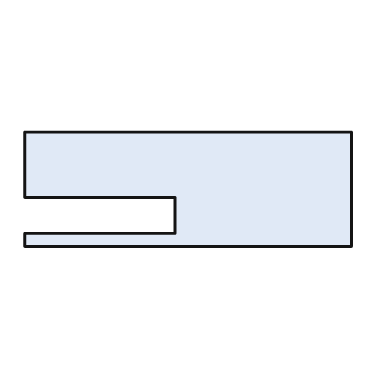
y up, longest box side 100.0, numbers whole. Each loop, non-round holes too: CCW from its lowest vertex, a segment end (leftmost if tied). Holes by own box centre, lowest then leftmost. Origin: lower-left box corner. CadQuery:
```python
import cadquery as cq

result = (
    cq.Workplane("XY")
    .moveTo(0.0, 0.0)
    .lineTo(100.0, 0.0)
    .lineTo(100.0, 35.0)
    .lineTo(0.0, 35.0)
    .lineTo(0.0, 15.0)
    .lineTo(46.0, 15.0)
    .lineTo(46.0, 4.0)
    .lineTo(0.0, 4.0)
    .close()
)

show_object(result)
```